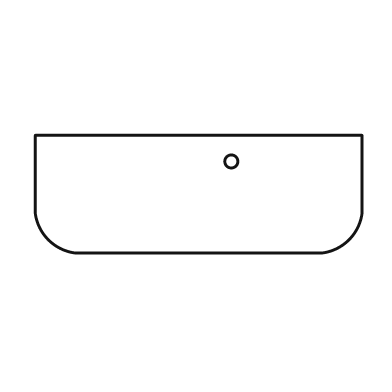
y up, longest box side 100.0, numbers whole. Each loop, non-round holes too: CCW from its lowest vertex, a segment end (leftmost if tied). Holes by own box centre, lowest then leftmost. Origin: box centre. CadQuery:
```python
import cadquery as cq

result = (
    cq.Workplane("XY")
    .moveTo(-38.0, -18.0)
    .lineTo(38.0, -18.0)
    .threePointArc((46.0, -14.0), (50.0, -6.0))
    .lineTo(50.0, 18.0)
    .lineTo(-50.0, 18.0)
    .lineTo(-50.0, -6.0)
    .threePointArc((-46.0, -14.0), (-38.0, -18.0))
    .close()
    .moveTo(10.0, 10.0)
    .circle(2.0)
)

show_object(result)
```